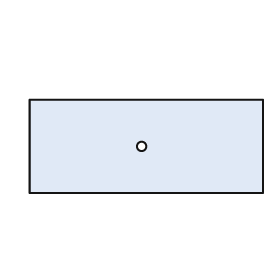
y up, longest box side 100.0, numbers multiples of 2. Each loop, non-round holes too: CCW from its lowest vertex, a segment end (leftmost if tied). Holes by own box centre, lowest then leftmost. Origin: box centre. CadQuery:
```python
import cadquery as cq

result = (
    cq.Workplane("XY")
    .moveTo(-50.0, -20.0)
    .lineTo(50.0, -20.0)
    .lineTo(50.0, 20.0)
    .lineTo(-50.0, 20.0)
    .close()
    .moveTo(-2.0, 0.0)
    .circle(2.0)
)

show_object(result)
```